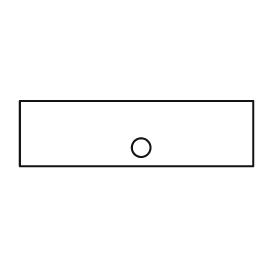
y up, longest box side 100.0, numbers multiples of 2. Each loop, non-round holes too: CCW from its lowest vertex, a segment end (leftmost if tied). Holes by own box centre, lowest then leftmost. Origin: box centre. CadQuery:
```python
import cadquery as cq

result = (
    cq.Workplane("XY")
    .moveTo(-50.0, -14.0)
    .lineTo(50.0, -14.0)
    .lineTo(50.0, 14.0)
    .lineTo(-50.0, 14.0)
    .close()
    .moveTo(2.0, -6.0)
    .circle(4.0)
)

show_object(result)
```